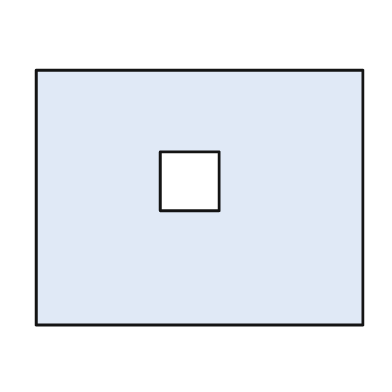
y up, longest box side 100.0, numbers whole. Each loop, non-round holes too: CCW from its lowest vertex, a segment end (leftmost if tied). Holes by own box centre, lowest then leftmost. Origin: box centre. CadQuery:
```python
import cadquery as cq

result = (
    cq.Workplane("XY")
    .moveTo(-50.0, -39.0)
    .lineTo(50.0, -39.0)
    .lineTo(50.0, 39.0)
    .lineTo(-50.0, 39.0)
    .close()
    .moveTo(-12.0, -4.0)
    .lineTo(6.0, -4.0)
    .lineTo(6.0, 14.0)
    .lineTo(-12.0, 14.0)
    .close()
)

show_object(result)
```